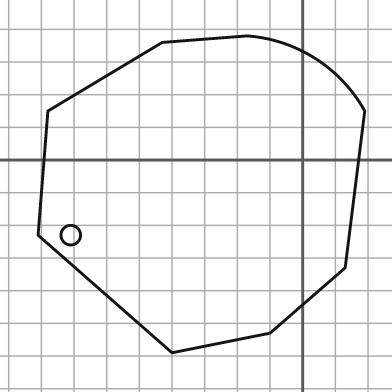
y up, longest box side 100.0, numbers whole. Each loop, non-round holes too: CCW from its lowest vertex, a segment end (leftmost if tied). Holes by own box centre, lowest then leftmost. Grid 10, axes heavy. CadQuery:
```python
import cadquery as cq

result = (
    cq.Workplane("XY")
    .moveTo(-40.0, -59.0)
    .lineTo(-10.0, -53.0)
    .lineTo(13.0, -33.0)
    .lineTo(19.0, 15.0)
    .threePointArc((4.0, 31.0), (-17.0, 38.0))
    .lineTo(-43.0, 36.0)
    .lineTo(-78.0, 15.0)
    .lineTo(-81.0, -23.0)
    .close()
    .moveTo(-71.0, -23.0)
    .circle(3.0)
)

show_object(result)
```